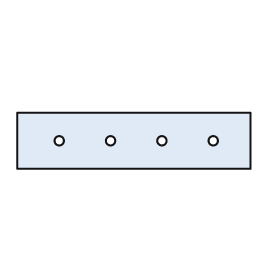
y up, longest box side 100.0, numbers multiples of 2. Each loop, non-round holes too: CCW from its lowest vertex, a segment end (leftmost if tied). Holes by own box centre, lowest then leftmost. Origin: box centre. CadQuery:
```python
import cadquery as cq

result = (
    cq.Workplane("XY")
    .moveTo(-50.0, -12.0)
    .lineTo(50.0, -12.0)
    .lineTo(50.0, 12.0)
    .lineTo(-50.0, 12.0)
    .close()
    .moveTo(-32.0, 0.0)
    .circle(2.0)
    .moveTo(-10.0, 0.0)
    .circle(2.0)
    .moveTo(12.0, 0.0)
    .circle(2.0)
    .moveTo(34.0, 0.0)
    .circle(2.0)
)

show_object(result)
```